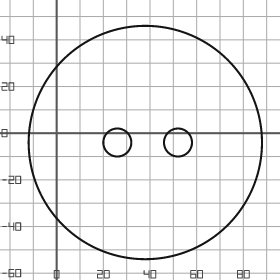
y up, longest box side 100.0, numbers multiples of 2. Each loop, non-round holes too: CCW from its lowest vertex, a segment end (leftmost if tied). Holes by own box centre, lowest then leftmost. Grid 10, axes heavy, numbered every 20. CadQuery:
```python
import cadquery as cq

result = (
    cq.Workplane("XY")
    .moveTo(38.0, -4.0)
    .circle(50.0)
    .moveTo(26.0, -4.0)
    .circle(6.0)
    .moveTo(52.0, -4.0)
    .circle(6.0)
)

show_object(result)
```